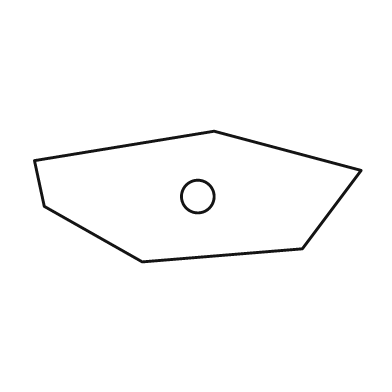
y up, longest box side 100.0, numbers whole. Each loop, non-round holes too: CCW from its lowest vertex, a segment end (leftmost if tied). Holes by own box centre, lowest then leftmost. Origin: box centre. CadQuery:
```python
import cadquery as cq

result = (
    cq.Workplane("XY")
    .moveTo(-17.0, -20.0)
    .lineTo(32.0, -16.0)
    .lineTo(50.0, 8.0)
    .lineTo(5.0, 20.0)
    .lineTo(-50.0, 11.0)
    .lineTo(-47.0, -3.0)
    .close()
    .moveTo(0.0, 0.0)
    .circle(5.0)
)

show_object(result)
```